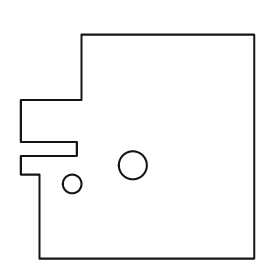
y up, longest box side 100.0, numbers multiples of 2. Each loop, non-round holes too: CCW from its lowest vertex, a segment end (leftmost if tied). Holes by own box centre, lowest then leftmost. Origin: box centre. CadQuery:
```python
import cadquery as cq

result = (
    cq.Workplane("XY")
    .moveTo(-42.0, -48.0)
    .lineTo(50.0, -48.0)
    .lineTo(50.0, 48.0)
    .lineTo(-24.0, 48.0)
    .lineTo(-24.0, 20.0)
    .lineTo(-50.0, 20.0)
    .lineTo(-50.0, 2.0)
    .lineTo(-26.0, 2.0)
    .lineTo(-26.0, -4.0)
    .lineTo(-50.0, -4.0)
    .lineTo(-50.0, -12.0)
    .lineTo(-42.0, -12.0)
    .close()
    .moveTo(-28.0, -16.0)
    .circle(4.0)
    .moveTo(-2.0, -8.0)
    .circle(6.0)
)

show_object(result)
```